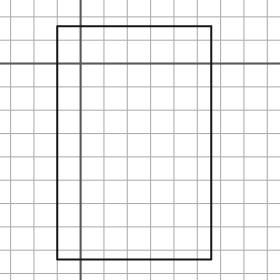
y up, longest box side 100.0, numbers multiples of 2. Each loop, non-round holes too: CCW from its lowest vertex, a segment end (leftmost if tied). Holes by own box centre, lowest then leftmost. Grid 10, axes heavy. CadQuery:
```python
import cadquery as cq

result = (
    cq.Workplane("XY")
    .moveTo(-10.0, -84.0)
    .lineTo(56.0, -84.0)
    .lineTo(56.0, 16.0)
    .lineTo(-10.0, 16.0)
    .close()
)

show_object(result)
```